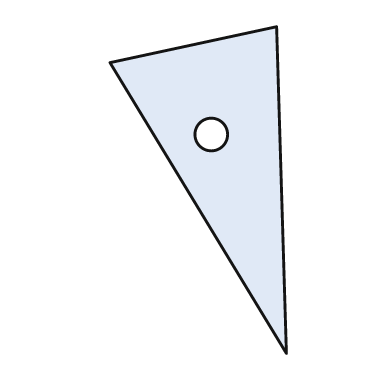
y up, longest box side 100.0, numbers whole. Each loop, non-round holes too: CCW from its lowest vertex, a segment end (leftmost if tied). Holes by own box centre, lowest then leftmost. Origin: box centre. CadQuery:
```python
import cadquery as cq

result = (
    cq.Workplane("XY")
    .moveTo(27.0, -50.0)
    .lineTo(24.0, 50.0)
    .lineTo(-27.0, 39.0)
    .close()
    .moveTo(4.0, 17.0)
    .circle(5.0)
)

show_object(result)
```